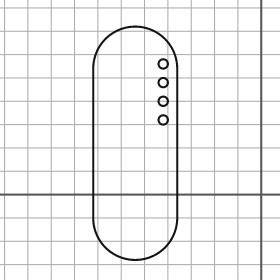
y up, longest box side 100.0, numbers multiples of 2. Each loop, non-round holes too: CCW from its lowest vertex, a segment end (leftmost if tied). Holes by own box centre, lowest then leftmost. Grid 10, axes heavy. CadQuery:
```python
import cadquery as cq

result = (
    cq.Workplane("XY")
    .moveTo(-72.0, -10.0)
    .threePointArc((-54.0, -28.0), (-36.0, -10.0))
    .lineTo(-36.0, 54.0)
    .threePointArc((-54.0, 72.0), (-72.0, 54.0))
    .close()
    .moveTo(-42.0, 32.0)
    .circle(2.0)
    .moveTo(-42.0, 40.0)
    .circle(2.0)
    .moveTo(-42.0, 48.0)
    .circle(2.0)
    .moveTo(-42.0, 56.0)
    .circle(2.0)
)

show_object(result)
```